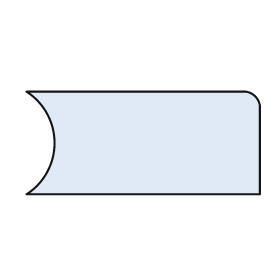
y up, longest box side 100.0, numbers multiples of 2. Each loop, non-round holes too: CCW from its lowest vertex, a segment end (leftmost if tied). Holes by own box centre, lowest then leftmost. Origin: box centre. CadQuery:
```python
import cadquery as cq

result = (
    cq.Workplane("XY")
    .moveTo(-50.0, -22.0)
    .lineTo(50.0, -22.0)
    .lineTo(50.0, 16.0)
    .threePointArc((48.0, 20.0), (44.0, 22.0))
    .lineTo(-50.0, 22.0)
    .threePointArc((-38.0, 0.0), (-50.0, -22.0))
    .close()
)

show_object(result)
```